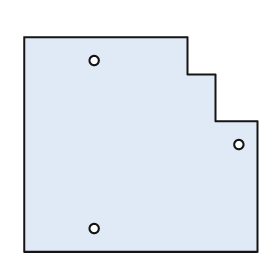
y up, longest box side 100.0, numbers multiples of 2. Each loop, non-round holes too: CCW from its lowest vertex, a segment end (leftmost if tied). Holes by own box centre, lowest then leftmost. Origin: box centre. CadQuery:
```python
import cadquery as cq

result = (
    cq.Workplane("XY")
    .moveTo(-50.0, -46.0)
    .lineTo(50.0, -46.0)
    .lineTo(50.0, 10.0)
    .lineTo(32.0, 10.0)
    .lineTo(32.0, 30.0)
    .lineTo(20.0, 30.0)
    .lineTo(20.0, 46.0)
    .lineTo(-50.0, 46.0)
    .close()
    .moveTo(-20.0, -36.0)
    .circle(2.0)
    .moveTo(42.0, 0.0)
    .circle(2.0)
    .moveTo(-20.0, 36.0)
    .circle(2.0)
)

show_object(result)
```